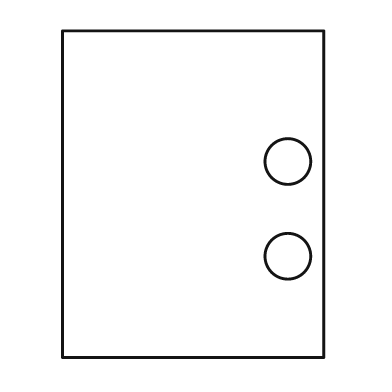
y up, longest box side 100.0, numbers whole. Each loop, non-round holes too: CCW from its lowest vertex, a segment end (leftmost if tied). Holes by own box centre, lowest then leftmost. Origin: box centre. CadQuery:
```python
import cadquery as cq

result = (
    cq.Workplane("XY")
    .moveTo(-40.0, -50.0)
    .lineTo(40.0, -50.0)
    .lineTo(40.0, 50.0)
    .lineTo(-40.0, 50.0)
    .close()
    .moveTo(29.0, -19.0)
    .circle(7.0)
    .moveTo(29.0, 10.0)
    .circle(7.0)
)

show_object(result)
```